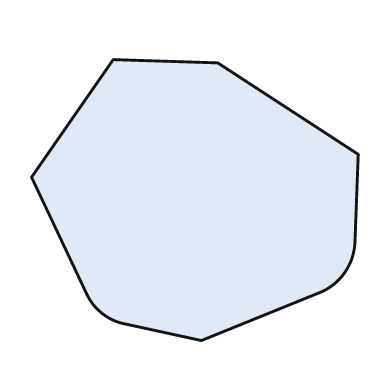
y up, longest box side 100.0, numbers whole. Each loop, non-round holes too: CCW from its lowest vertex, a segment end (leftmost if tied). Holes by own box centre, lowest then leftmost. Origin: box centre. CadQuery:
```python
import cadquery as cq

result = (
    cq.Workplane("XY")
    .moveTo(2.0, -43.0)
    .lineTo(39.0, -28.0)
    .threePointArc((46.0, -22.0), (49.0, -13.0))
    .lineTo(50.0, 14.0)
    .lineTo(7.0, 42.0)
    .lineTo(-25.0, 43.0)
    .lineTo(-50.0, 7.0)
    .lineTo(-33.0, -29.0)
    .threePointArc((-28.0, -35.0), (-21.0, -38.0))
    .close()
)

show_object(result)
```